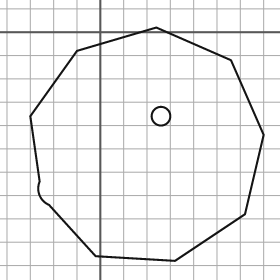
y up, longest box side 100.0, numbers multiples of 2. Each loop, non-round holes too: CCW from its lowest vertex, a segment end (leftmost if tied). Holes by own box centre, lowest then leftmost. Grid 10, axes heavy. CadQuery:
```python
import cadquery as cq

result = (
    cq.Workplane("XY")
    .moveTo(32.0, -98.0)
    .lineTo(62.0, -78.0)
    .lineTo(70.0, -44.0)
    .lineTo(56.0, -12.0)
    .lineTo(24.0, 2.0)
    .lineTo(-10.0, -8.0)
    .lineTo(-30.0, -36.0)
    .lineTo(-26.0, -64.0)
    .threePointArc((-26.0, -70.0), (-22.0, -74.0))
    .lineTo(-2.0, -96.0)
    .close()
    .moveTo(26.0, -36.0)
    .circle(4.0)
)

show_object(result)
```